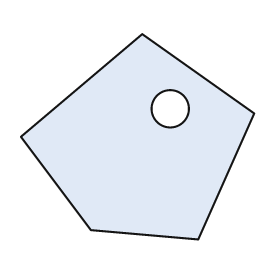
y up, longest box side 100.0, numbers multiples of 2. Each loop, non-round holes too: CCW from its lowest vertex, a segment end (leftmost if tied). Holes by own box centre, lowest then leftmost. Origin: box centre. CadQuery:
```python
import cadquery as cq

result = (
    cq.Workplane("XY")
    .moveTo(26.0, -44.0)
    .lineTo(50.0, 10.0)
    .lineTo(2.0, 44.0)
    .lineTo(-50.0, 0.0)
    .lineTo(-20.0, -40.0)
    .close()
    .moveTo(14.0, 12.0)
    .circle(8.0)
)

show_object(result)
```